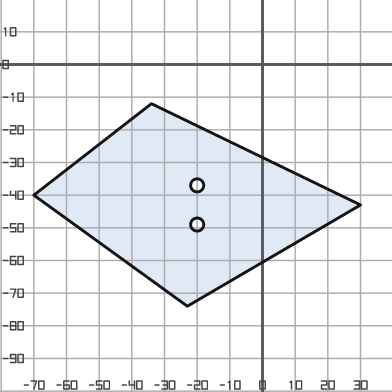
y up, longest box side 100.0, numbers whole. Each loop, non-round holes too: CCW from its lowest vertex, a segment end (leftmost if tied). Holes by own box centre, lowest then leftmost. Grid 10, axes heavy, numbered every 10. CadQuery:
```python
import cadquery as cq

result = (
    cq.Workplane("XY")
    .moveTo(-23.0, -74.0)
    .lineTo(30.0, -43.0)
    .lineTo(-34.0, -12.0)
    .lineTo(-70.0, -40.0)
    .close()
    .moveTo(-20.0, -49.0)
    .circle(2.0)
    .moveTo(-20.0, -37.0)
    .circle(2.0)
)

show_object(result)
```